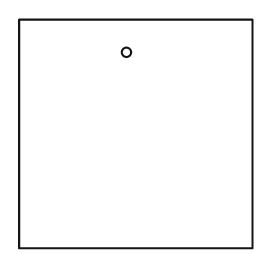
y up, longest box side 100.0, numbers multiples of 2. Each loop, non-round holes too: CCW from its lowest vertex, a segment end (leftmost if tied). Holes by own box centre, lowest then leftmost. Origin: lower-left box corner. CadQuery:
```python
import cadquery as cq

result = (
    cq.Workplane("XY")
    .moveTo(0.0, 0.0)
    .lineTo(100.0, 0.0)
    .lineTo(100.0, 98.0)
    .lineTo(0.0, 98.0)
    .close()
    .moveTo(46.0, 84.0)
    .circle(2.0)
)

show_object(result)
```